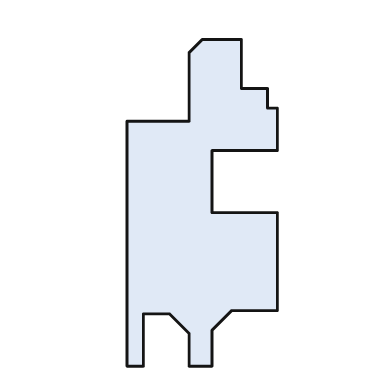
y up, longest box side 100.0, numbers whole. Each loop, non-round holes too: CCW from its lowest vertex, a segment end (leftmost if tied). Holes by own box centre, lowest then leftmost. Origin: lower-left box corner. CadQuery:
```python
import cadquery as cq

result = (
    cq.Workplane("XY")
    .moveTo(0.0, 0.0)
    .lineTo(5.0, 0.0)
    .lineTo(5.0, 16.0)
    .lineTo(13.0, 16.0)
    .lineTo(19.0, 10.0)
    .lineTo(19.0, 0.0)
    .lineTo(26.0, 0.0)
    .lineTo(26.0, 11.0)
    .lineTo(32.0, 17.0)
    .lineTo(46.0, 17.0)
    .lineTo(46.0, 47.0)
    .lineTo(26.0, 47.0)
    .lineTo(26.0, 66.0)
    .lineTo(46.0, 66.0)
    .lineTo(46.0, 79.0)
    .lineTo(43.0, 79.0)
    .lineTo(43.0, 85.0)
    .lineTo(35.0, 85.0)
    .lineTo(35.0, 100.0)
    .lineTo(23.0, 100.0)
    .lineTo(19.0, 96.0)
    .lineTo(19.0, 75.0)
    .lineTo(0.0, 75.0)
    .close()
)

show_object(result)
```